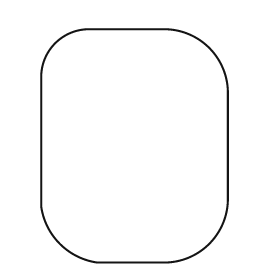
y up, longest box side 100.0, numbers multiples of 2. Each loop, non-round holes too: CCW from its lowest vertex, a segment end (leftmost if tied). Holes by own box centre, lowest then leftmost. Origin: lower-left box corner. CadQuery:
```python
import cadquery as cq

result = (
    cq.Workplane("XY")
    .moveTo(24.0, 0.0)
    .lineTo(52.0, 0.0)
    .threePointArc((72.0, 8.0), (80.0, 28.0))
    .lineTo(80.0, 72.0)
    .threePointArc((72.0, 92.0), (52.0, 100.0))
    .lineTo(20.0, 100.0)
    .threePointArc((6.0, 94.0), (0.0, 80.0))
    .lineTo(0.0, 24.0)
    .threePointArc((8.0, 8.0), (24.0, 0.0))
    .close()
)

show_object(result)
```